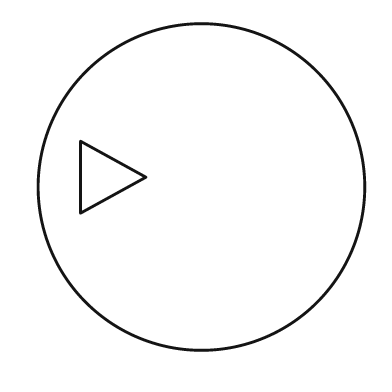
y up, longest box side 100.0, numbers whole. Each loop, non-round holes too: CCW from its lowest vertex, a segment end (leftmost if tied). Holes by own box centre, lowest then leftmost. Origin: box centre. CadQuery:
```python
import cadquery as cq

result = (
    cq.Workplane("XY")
    .moveTo(0.0, 0.0)
    .circle(50.0)
    .moveTo(-37.0, -8.0)
    .lineTo(-17.0, 3.0)
    .lineTo(-37.0, 14.0)
    .close()
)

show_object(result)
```